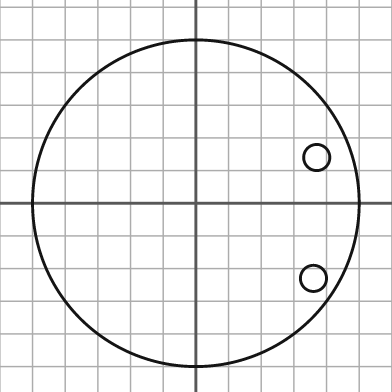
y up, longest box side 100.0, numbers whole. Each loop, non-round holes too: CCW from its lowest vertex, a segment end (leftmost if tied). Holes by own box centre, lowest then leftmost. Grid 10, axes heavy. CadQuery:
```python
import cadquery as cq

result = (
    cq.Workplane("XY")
    .moveTo(0.0, 0.0)
    .circle(50.0)
    .moveTo(36.0, -23.0)
    .circle(4.0)
    .moveTo(37.0, 14.0)
    .circle(4.0)
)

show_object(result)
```